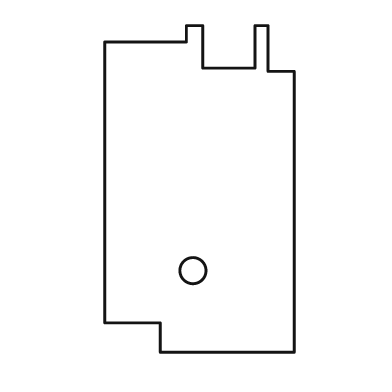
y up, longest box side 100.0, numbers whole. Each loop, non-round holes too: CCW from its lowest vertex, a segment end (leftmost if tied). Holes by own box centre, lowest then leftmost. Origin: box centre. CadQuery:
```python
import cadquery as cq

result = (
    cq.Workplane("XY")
    .moveTo(-12.0, -50.0)
    .lineTo(29.0, -50.0)
    .lineTo(29.0, 36.0)
    .lineTo(21.0, 36.0)
    .lineTo(21.0, 50.0)
    .lineTo(17.0, 50.0)
    .lineTo(17.0, 37.0)
    .lineTo(1.0, 37.0)
    .lineTo(1.0, 50.0)
    .lineTo(-4.0, 50.0)
    .lineTo(-4.0, 45.0)
    .lineTo(-29.0, 45.0)
    .lineTo(-29.0, -41.0)
    .lineTo(-12.0, -41.0)
    .close()
    .moveTo(-2.0, -25.0)
    .circle(4.0)
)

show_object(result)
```